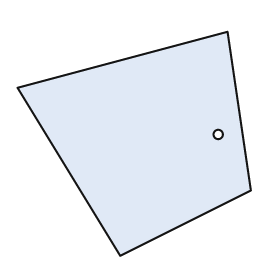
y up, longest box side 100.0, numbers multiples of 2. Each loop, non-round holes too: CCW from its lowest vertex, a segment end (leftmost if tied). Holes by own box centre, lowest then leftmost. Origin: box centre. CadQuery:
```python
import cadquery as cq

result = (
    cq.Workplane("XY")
    .moveTo(-6.0, -48.0)
    .lineTo(50.0, -20.0)
    .lineTo(40.0, 48.0)
    .lineTo(-50.0, 24.0)
    .close()
    .moveTo(36.0, 4.0)
    .circle(2.0)
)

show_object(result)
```